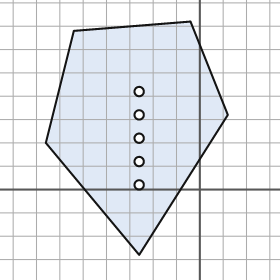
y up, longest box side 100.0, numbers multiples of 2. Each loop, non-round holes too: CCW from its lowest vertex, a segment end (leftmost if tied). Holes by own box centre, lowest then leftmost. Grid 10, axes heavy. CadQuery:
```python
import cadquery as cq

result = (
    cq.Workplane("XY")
    .moveTo(-26.0, -28.0)
    .lineTo(12.0, 32.0)
    .lineTo(-4.0, 72.0)
    .lineTo(-54.0, 68.0)
    .lineTo(-66.0, 20.0)
    .close()
    .moveTo(-26.0, 2.0)
    .circle(2.0)
    .moveTo(-26.0, 12.0)
    .circle(2.0)
    .moveTo(-26.0, 22.0)
    .circle(2.0)
    .moveTo(-26.0, 32.0)
    .circle(2.0)
    .moveTo(-26.0, 42.0)
    .circle(2.0)
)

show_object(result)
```